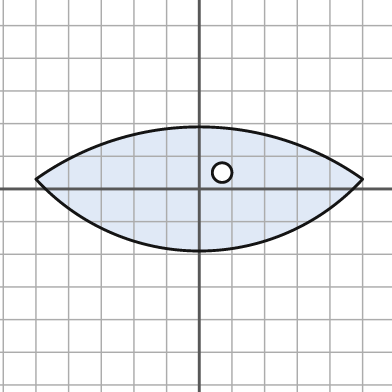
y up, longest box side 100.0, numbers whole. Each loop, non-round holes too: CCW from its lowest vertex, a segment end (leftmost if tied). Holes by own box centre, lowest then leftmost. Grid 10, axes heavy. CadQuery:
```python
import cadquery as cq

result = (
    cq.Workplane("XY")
    .moveTo(-50.0, 3.0)
    .threePointArc((0.0, -19.0), (50.0, 3.0))
    .threePointArc((0.0, 19.0), (-50.0, 3.0))
    .close()
    .moveTo(7.0, 5.0)
    .circle(3.0)
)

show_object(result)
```